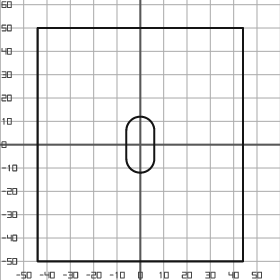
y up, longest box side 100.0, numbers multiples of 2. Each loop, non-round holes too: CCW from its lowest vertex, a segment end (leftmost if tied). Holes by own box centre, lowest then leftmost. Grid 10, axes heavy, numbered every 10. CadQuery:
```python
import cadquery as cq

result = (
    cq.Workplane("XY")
    .moveTo(-44.0, -50.0)
    .lineTo(44.0, -50.0)
    .lineTo(44.0, 50.0)
    .lineTo(-44.0, 50.0)
    .close()
    .moveTo(-6.0, -6.0)
    .threePointArc((0.0, -12.0), (6.0, -6.0))
    .lineTo(6.0, 6.0)
    .threePointArc((0.0, 12.0), (-6.0, 6.0))
    .close()
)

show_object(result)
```